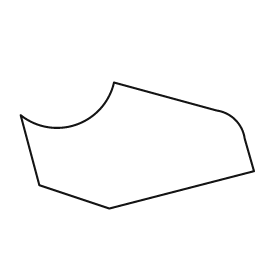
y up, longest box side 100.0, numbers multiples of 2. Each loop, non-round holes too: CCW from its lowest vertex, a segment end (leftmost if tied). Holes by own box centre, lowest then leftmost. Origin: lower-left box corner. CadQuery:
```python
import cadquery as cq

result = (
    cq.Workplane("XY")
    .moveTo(38.0, 0.0)
    .lineTo(100.0, 16.0)
    .lineTo(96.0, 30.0)
    .threePointArc((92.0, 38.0), (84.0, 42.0))
    .lineTo(40.0, 54.0)
    .threePointArc((24.0, 36.0), (0.0, 40.0))
    .lineTo(8.0, 10.0)
    .close()
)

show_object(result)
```